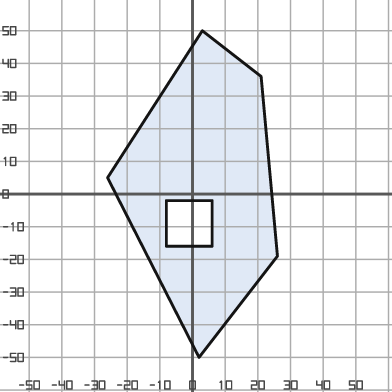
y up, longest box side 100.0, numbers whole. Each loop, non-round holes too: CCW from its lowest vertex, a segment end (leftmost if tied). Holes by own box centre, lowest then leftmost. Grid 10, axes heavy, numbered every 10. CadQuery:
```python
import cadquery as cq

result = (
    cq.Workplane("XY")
    .moveTo(2.0, -50.0)
    .lineTo(26.0, -19.0)
    .lineTo(21.0, 36.0)
    .lineTo(3.0, 50.0)
    .lineTo(-26.0, 5.0)
    .close()
    .moveTo(-8.0, -16.0)
    .lineTo(6.0, -16.0)
    .lineTo(6.0, -2.0)
    .lineTo(-8.0, -2.0)
    .close()
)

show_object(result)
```